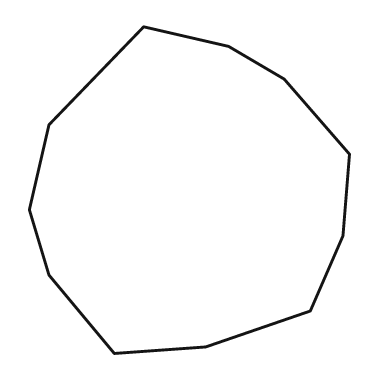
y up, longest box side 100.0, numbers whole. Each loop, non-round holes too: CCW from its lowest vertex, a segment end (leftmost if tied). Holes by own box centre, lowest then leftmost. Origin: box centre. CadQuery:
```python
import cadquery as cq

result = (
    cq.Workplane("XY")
    .moveTo(-23.0, -50.0)
    .lineTo(5.0, -48.0)
    .lineTo(37.0, -37.0)
    .lineTo(47.0, -14.0)
    .lineTo(49.0, 11.0)
    .lineTo(29.0, 34.0)
    .lineTo(12.0, 44.0)
    .lineTo(-14.0, 50.0)
    .lineTo(-43.0, 20.0)
    .lineTo(-49.0, -6.0)
    .lineTo(-43.0, -26.0)
    .close()
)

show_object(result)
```